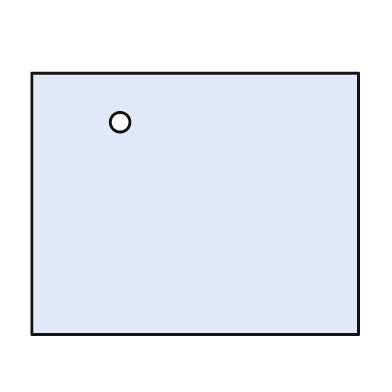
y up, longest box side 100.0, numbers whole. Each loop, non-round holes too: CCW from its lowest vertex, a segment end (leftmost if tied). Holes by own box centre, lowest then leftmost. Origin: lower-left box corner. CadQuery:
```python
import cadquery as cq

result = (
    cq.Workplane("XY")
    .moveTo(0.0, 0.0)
    .lineTo(100.0, 0.0)
    .lineTo(100.0, 80.0)
    .lineTo(0.0, 80.0)
    .close()
    .moveTo(27.0, 65.0)
    .circle(3.0)
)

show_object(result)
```